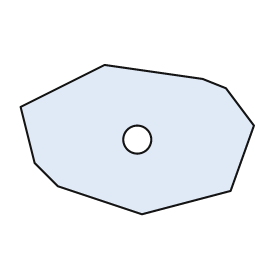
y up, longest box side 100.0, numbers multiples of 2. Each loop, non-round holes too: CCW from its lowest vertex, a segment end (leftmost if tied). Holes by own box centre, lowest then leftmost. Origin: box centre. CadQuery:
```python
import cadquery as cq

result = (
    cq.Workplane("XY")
    .moveTo(2.0, -32.0)
    .lineTo(40.0, -22.0)
    .lineTo(50.0, 6.0)
    .lineTo(38.0, 22.0)
    .lineTo(28.0, 26.0)
    .lineTo(-14.0, 32.0)
    .lineTo(-50.0, 14.0)
    .lineTo(-44.0, -10.0)
    .lineTo(-34.0, -20.0)
    .close()
    .moveTo(0.0, 0.0)
    .circle(6.0)
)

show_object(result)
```